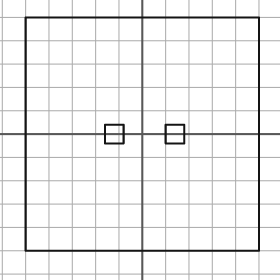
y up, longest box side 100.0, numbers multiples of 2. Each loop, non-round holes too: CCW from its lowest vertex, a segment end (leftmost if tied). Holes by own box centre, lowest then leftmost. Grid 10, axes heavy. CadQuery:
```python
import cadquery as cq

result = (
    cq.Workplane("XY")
    .moveTo(-50.0, -50.0)
    .lineTo(50.0, -50.0)
    .lineTo(50.0, 50.0)
    .lineTo(-50.0, 50.0)
    .close()
    .moveTo(-16.0, -4.0)
    .lineTo(-8.0, -4.0)
    .lineTo(-8.0, 4.0)
    .lineTo(-16.0, 4.0)
    .close()
    .moveTo(10.0, -4.0)
    .lineTo(18.0, -4.0)
    .lineTo(18.0, 4.0)
    .lineTo(10.0, 4.0)
    .close()
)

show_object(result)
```